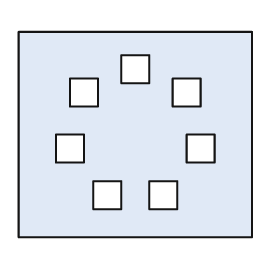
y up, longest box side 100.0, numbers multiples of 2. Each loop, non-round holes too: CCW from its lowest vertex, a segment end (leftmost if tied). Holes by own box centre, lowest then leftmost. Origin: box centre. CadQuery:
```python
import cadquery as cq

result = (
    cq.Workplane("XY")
    .moveTo(-50.0, -44.0)
    .lineTo(50.0, -44.0)
    .lineTo(50.0, 44.0)
    .lineTo(-50.0, 44.0)
    .close()
    .moveTo(-18.0, -32.0)
    .lineTo(-6.0, -32.0)
    .lineTo(-6.0, -20.0)
    .lineTo(-18.0, -20.0)
    .close()
    .moveTo(6.0, -32.0)
    .lineTo(18.0, -32.0)
    .lineTo(18.0, -20.0)
    .lineTo(6.0, -20.0)
    .close()
    .moveTo(-34.0, -12.0)
    .lineTo(-22.0, -12.0)
    .lineTo(-22.0, 0.0)
    .lineTo(-34.0, 0.0)
    .close()
    .moveTo(22.0, -12.0)
    .lineTo(34.0, -12.0)
    .lineTo(34.0, 0.0)
    .lineTo(22.0, 0.0)
    .close()
    .moveTo(-28.0, 12.0)
    .lineTo(-16.0, 12.0)
    .lineTo(-16.0, 24.0)
    .lineTo(-28.0, 24.0)
    .close()
    .moveTo(16.0, 12.0)
    .lineTo(28.0, 12.0)
    .lineTo(28.0, 24.0)
    .lineTo(16.0, 24.0)
    .close()
    .moveTo(-6.0, 22.0)
    .lineTo(6.0, 22.0)
    .lineTo(6.0, 34.0)
    .lineTo(-6.0, 34.0)
    .close()
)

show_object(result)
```